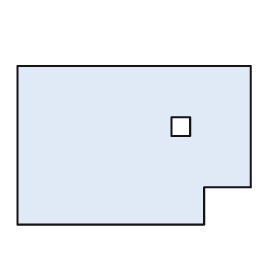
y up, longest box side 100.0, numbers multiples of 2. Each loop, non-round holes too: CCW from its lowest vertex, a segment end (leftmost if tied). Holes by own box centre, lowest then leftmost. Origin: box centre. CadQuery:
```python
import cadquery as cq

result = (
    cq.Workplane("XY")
    .moveTo(-50.0, -34.0)
    .lineTo(30.0, -34.0)
    .lineTo(30.0, -18.0)
    .lineTo(50.0, -18.0)
    .lineTo(50.0, 34.0)
    .lineTo(-50.0, 34.0)
    .close()
    .moveTo(16.0, 4.0)
    .lineTo(24.0, 4.0)
    .lineTo(24.0, 12.0)
    .lineTo(16.0, 12.0)
    .close()
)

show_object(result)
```